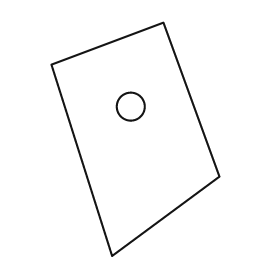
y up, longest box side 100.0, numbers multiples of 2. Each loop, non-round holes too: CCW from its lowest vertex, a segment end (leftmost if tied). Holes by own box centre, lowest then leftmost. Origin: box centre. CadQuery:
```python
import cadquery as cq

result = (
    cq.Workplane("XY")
    .moveTo(-10.0, -50.0)
    .lineTo(36.0, -16.0)
    .lineTo(12.0, 50.0)
    .lineTo(-36.0, 32.0)
    .close()
    .moveTo(-2.0, 14.0)
    .circle(6.0)
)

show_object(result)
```